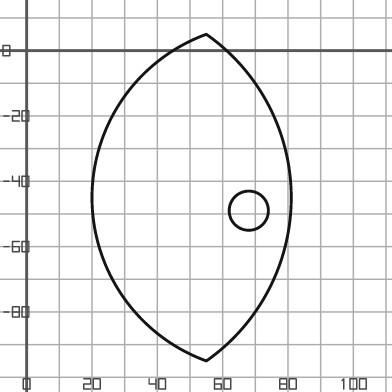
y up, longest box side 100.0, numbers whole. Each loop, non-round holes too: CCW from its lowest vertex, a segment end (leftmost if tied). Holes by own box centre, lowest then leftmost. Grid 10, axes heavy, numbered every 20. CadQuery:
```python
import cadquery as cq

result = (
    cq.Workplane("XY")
    .moveTo(55.0, -95.0)
    .threePointArc((81.0, -45.0), (55.0, 5.0))
    .threePointArc((20.0, -45.0), (55.0, -95.0))
    .close()
    .moveTo(68.0, -49.0)
    .circle(6.0)
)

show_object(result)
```